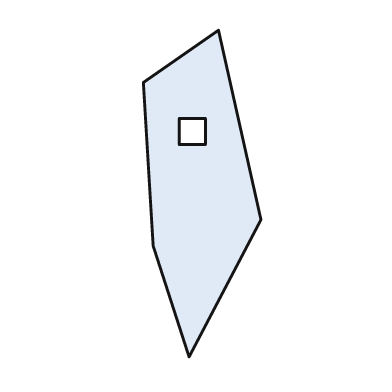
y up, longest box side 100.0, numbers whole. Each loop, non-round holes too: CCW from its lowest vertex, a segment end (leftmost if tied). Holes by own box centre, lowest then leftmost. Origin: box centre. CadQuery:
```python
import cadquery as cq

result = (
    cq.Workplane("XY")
    .moveTo(-4.0, -50.0)
    .lineTo(18.0, -8.0)
    .lineTo(5.0, 50.0)
    .lineTo(-18.0, 34.0)
    .lineTo(-15.0, -16.0)
    .close()
    .moveTo(-7.0, 15.0)
    .lineTo(1.0, 15.0)
    .lineTo(1.0, 23.0)
    .lineTo(-7.0, 23.0)
    .close()
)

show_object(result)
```